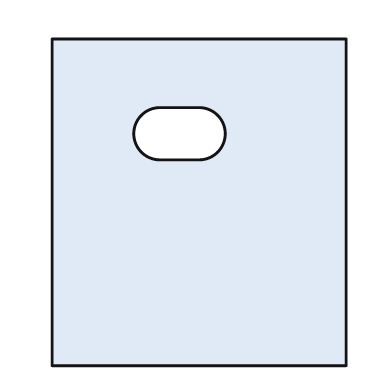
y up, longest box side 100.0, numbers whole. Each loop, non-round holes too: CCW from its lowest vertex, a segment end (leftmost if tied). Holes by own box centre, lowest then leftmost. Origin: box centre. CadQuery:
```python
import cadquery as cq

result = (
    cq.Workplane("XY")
    .moveTo(-45.0, -50.0)
    .lineTo(45.0, -50.0)
    .lineTo(45.0, 50.0)
    .lineTo(-45.0, 50.0)
    .close()
    .moveTo(-12.0, 13.0)
    .lineTo(0.0, 13.0)
    .threePointArc((8.0, 21.0), (0.0, 29.0))
    .lineTo(-12.0, 29.0)
    .threePointArc((-20.0, 21.0), (-12.0, 13.0))
    .close()
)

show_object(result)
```